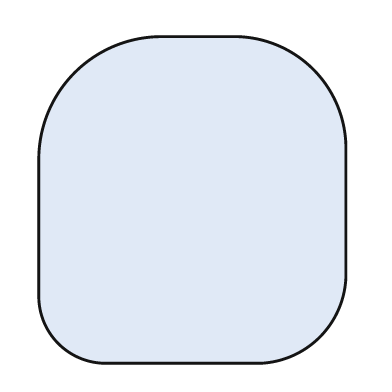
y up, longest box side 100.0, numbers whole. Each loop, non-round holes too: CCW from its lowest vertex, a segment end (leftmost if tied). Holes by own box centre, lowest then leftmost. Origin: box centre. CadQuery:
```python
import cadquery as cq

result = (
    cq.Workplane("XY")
    .moveTo(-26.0, -50.0)
    .lineTo(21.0, -50.0)
    .threePointArc((39.0, -42.0), (47.0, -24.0))
    .lineTo(47.0, 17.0)
    .threePointArc((37.0, 40.0), (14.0, 50.0))
    .lineTo(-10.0, 50.0)
    .threePointArc((-36.0, 39.0), (-47.0, 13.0))
    .lineTo(-47.0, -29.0)
    .threePointArc((-41.0, -44.0), (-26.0, -50.0))
    .close()
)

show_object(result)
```